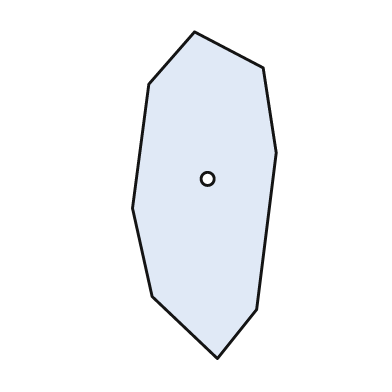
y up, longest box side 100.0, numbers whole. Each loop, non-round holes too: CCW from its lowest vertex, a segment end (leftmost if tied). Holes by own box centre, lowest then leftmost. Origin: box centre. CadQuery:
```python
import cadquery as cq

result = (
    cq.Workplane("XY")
    .moveTo(4.0, -50.0)
    .lineTo(16.0, -35.0)
    .lineTo(22.0, 13.0)
    .lineTo(18.0, 39.0)
    .lineTo(-3.0, 50.0)
    .lineTo(-17.0, 34.0)
    .lineTo(-22.0, -4.0)
    .lineTo(-16.0, -31.0)
    .close()
    .moveTo(1.0, 5.0)
    .circle(2.0)
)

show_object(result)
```